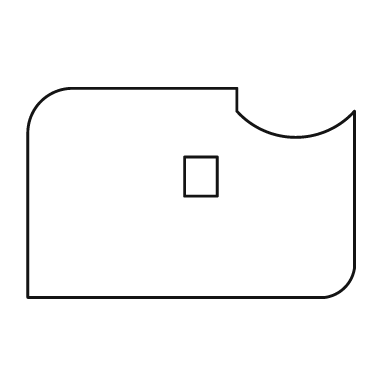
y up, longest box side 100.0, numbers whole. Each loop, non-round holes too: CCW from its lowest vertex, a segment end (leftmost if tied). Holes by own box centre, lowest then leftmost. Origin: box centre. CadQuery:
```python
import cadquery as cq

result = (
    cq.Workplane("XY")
    .moveTo(-50.0, -32.0)
    .lineTo(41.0, -32.0)
    .threePointArc((47.0, -29.0), (50.0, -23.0))
    .lineTo(50.0, 25.0)
    .threePointArc((32.0, 17.0), (14.0, 25.0))
    .lineTo(14.0, 32.0)
    .lineTo(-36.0, 32.0)
    .threePointArc((-46.0, 28.0), (-50.0, 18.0))
    .close()
    .moveTo(-2.0, -1.0)
    .lineTo(8.0, -1.0)
    .lineTo(8.0, 11.0)
    .lineTo(-2.0, 11.0)
    .close()
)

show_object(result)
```